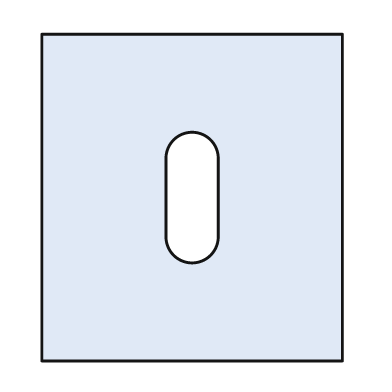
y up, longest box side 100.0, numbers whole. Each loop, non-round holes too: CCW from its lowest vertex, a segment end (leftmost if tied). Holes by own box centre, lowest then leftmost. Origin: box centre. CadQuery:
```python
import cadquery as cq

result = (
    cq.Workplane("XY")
    .moveTo(-46.0, -50.0)
    .lineTo(46.0, -50.0)
    .lineTo(46.0, 50.0)
    .lineTo(-46.0, 50.0)
    .close()
    .moveTo(-8.0, -12.0)
    .threePointArc((0.0, -20.0), (8.0, -12.0))
    .lineTo(8.0, 12.0)
    .threePointArc((0.0, 20.0), (-8.0, 12.0))
    .close()
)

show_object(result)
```